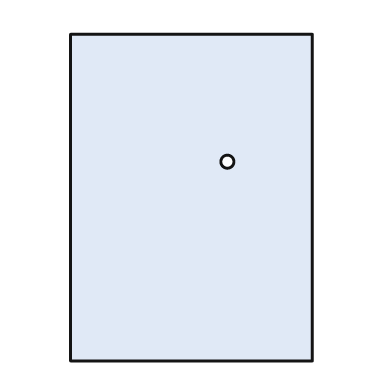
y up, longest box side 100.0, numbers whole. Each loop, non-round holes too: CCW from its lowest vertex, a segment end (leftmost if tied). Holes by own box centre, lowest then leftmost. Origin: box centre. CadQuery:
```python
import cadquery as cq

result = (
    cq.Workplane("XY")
    .moveTo(-37.0, -50.0)
    .lineTo(37.0, -50.0)
    .lineTo(37.0, 50.0)
    .lineTo(-37.0, 50.0)
    .close()
    .moveTo(11.0, 11.0)
    .circle(2.0)
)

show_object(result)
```